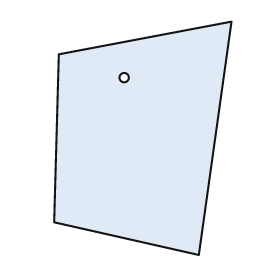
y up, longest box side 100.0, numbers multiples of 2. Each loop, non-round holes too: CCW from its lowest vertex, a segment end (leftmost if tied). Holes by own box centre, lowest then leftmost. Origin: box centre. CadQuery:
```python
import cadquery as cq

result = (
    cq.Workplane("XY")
    .moveTo(24.0, -50.0)
    .lineTo(38.0, 50.0)
    .lineTo(-36.0, 36.0)
    .lineTo(-38.0, -36.0)
    .close()
    .moveTo(-8.0, 26.0)
    .circle(2.0)
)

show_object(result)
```